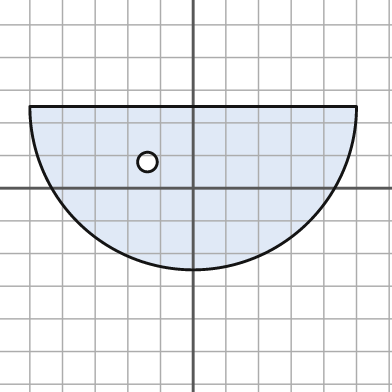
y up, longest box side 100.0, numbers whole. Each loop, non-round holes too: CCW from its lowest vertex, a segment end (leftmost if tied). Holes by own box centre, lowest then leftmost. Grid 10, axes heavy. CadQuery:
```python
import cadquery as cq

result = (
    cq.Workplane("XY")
    .moveTo(-50.0, 25.0)
    .threePointArc((0.0, -25.0), (50.0, 25.0))
    .close()
    .moveTo(-14.0, 8.0)
    .circle(3.0)
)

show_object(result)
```